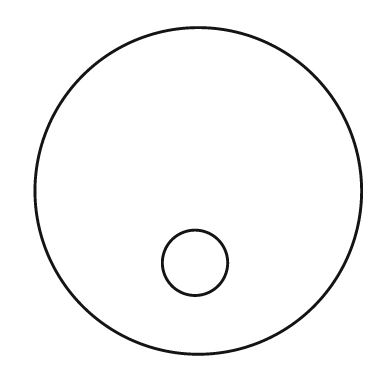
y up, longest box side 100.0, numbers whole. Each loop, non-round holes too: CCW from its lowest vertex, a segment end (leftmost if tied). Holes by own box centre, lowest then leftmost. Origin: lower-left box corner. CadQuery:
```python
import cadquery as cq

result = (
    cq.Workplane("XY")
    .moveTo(50.0, 50.0)
    .circle(50.0)
    .moveTo(49.0, 28.0)
    .circle(10.0)
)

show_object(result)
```